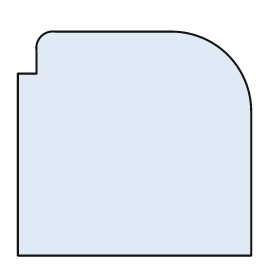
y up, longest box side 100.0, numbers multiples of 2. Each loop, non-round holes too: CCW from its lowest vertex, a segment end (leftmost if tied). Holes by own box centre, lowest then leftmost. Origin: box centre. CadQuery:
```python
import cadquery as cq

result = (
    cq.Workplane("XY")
    .moveTo(-50.0, -48.0)
    .lineTo(50.0, -48.0)
    .lineTo(50.0, 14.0)
    .threePointArc((40.0, 38.0), (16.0, 48.0))
    .lineTo(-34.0, 48.0)
    .threePointArc((-40.0, 46.0), (-42.0, 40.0))
    .lineTo(-42.0, 30.0)
    .lineTo(-50.0, 30.0)
    .close()
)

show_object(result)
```